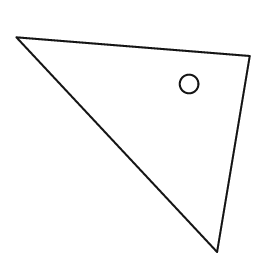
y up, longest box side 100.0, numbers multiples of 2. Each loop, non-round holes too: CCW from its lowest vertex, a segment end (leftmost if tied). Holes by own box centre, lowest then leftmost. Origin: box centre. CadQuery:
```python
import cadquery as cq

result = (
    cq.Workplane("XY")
    .moveTo(36.0, -46.0)
    .lineTo(50.0, 38.0)
    .lineTo(-50.0, 46.0)
    .close()
    .moveTo(24.0, 26.0)
    .circle(4.0)
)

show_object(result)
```